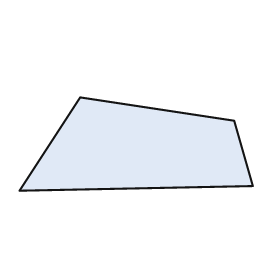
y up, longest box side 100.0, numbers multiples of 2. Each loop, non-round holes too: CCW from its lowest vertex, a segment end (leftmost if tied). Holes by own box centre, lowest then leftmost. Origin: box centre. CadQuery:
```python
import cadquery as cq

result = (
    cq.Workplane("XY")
    .moveTo(-50.0, -20.0)
    .lineTo(50.0, -18.0)
    .lineTo(42.0, 10.0)
    .lineTo(-24.0, 20.0)
    .close()
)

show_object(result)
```